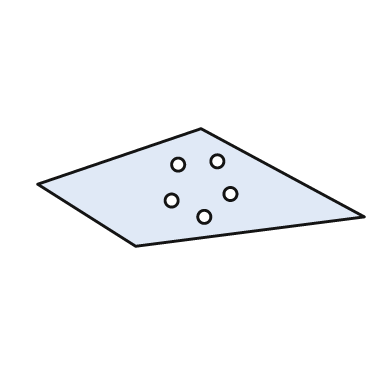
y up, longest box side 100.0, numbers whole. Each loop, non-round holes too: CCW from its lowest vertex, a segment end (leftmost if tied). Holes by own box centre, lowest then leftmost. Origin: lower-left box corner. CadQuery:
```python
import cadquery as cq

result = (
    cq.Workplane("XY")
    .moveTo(30.0, 0.0)
    .lineTo(100.0, 9.0)
    .lineTo(50.0, 36.0)
    .lineTo(0.0, 19.0)
    .close()
    .moveTo(51.0, 9.0)
    .circle(2.0)
    .moveTo(41.0, 14.0)
    .circle(2.0)
    .moveTo(59.0, 16.0)
    .circle(2.0)
    .moveTo(43.0, 25.0)
    .circle(2.0)
    .moveTo(55.0, 26.0)
    .circle(2.0)
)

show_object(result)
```